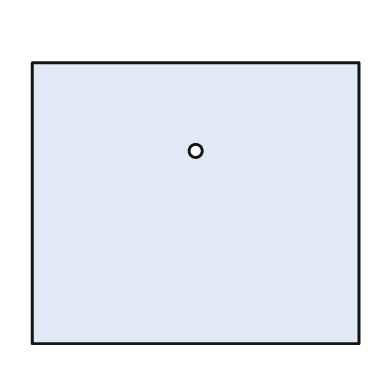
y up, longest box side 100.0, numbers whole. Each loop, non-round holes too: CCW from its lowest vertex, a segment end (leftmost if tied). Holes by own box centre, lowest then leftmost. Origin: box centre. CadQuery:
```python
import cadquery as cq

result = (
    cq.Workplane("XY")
    .moveTo(-50.0, -43.0)
    .lineTo(50.0, -43.0)
    .lineTo(50.0, 43.0)
    .lineTo(-50.0, 43.0)
    .close()
    .moveTo(0.0, 16.0)
    .circle(2.0)
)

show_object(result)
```